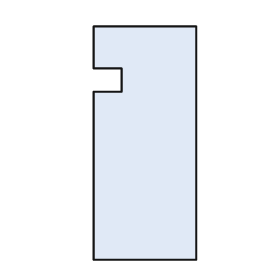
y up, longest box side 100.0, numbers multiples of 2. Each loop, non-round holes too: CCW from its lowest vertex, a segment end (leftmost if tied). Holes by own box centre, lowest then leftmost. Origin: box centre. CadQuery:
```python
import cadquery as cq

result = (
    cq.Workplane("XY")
    .moveTo(-22.0, -50.0)
    .lineTo(22.0, -50.0)
    .lineTo(22.0, 50.0)
    .lineTo(-22.0, 50.0)
    .lineTo(-22.0, 32.0)
    .lineTo(-10.0, 32.0)
    .lineTo(-10.0, 22.0)
    .lineTo(-22.0, 22.0)
    .close()
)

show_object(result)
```